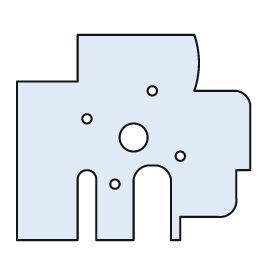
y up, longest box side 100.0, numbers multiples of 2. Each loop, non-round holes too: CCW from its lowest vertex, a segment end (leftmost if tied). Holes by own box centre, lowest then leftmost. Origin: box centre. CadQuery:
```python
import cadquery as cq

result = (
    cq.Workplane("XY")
    .moveTo(-50.0, -44.0)
    .lineTo(-24.0, -44.0)
    .lineTo(-24.0, -18.0)
    .threePointArc((-20.0, -14.0), (-16.0, -18.0))
    .lineTo(-16.0, -44.0)
    .lineTo(0.0, -44.0)
    .lineTo(0.0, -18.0)
    .threePointArc((2.0, -14.0), (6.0, -12.0))
    .lineTo(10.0, -12.0)
    .threePointArc((14.0, -14.0), (16.0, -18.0))
    .lineTo(16.0, -44.0)
    .lineTo(20.0, -44.0)
    .lineTo(20.0, -34.0)
    .lineTo(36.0, -34.0)
    .threePointArc((42.0, -32.0), (44.0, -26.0))
    .lineTo(44.0, -14.0)
    .lineTo(50.0, -14.0)
    .lineTo(50.0, 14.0)
    .threePointArc((48.0, 18.0), (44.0, 20.0))
    .lineTo(26.0, 20.0)
    .threePointArc((28.0, 32.0), (26.0, 44.0))
    .lineTo(-24.0, 44.0)
    .lineTo(-24.0, 24.0)
    .lineTo(-50.0, 24.0)
    .close()
    .moveTo(-8.0, -20.0)
    .circle(2.0)
    .moveTo(20.0, -8.0)
    .circle(2.0)
    .moveTo(0.0, 0.0)
    .circle(6.0)
    .moveTo(-20.0, 8.0)
    .circle(2.0)
    .moveTo(8.0, 20.0)
    .circle(2.0)
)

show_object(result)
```